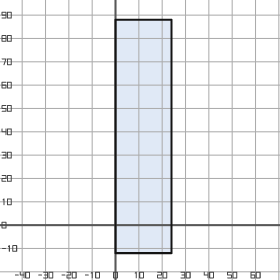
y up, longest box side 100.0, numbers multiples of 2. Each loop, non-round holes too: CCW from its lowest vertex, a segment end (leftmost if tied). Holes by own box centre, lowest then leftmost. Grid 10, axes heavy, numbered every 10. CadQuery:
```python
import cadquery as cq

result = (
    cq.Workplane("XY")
    .moveTo(0.0, -12.0)
    .lineTo(24.0, -12.0)
    .lineTo(24.0, 88.0)
    .lineTo(0.0, 88.0)
    .close()
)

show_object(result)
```